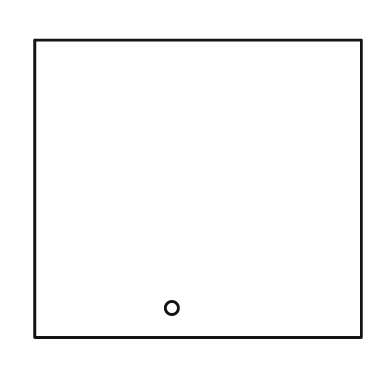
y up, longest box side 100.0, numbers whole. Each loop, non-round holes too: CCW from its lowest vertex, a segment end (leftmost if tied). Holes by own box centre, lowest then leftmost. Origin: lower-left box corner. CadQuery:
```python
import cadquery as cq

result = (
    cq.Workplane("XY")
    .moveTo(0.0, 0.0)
    .lineTo(100.0, 0.0)
    .lineTo(100.0, 91.0)
    .lineTo(0.0, 91.0)
    .close()
    .moveTo(42.0, 9.0)
    .circle(2.0)
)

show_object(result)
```